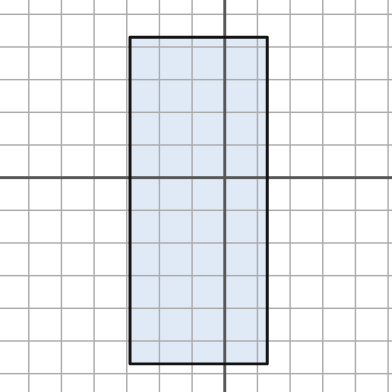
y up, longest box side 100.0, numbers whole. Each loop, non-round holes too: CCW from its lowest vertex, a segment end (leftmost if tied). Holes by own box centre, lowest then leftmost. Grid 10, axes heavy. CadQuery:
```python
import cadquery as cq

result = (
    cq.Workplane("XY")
    .moveTo(-29.0, -57.0)
    .lineTo(13.0, -57.0)
    .lineTo(13.0, 43.0)
    .lineTo(-29.0, 43.0)
    .close()
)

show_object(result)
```